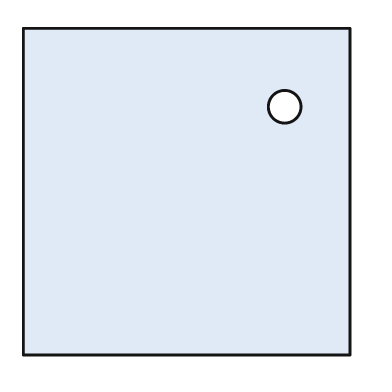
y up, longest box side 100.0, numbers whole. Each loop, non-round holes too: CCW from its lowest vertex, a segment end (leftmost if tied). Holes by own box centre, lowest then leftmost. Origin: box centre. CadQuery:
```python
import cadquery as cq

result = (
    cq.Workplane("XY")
    .moveTo(-50.0, -50.0)
    .lineTo(50.0, -50.0)
    .lineTo(50.0, 50.0)
    .lineTo(-50.0, 50.0)
    .close()
    .moveTo(30.0, 26.0)
    .circle(5.0)
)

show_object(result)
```